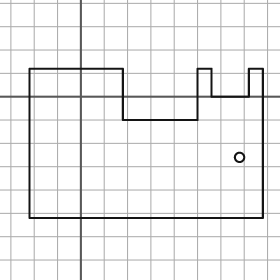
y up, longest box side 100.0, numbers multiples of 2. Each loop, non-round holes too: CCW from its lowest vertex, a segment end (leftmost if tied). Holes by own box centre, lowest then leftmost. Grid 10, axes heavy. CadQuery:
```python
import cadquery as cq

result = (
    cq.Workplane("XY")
    .moveTo(-22.0, -52.0)
    .lineTo(78.0, -52.0)
    .lineTo(78.0, 12.0)
    .lineTo(72.0, 12.0)
    .lineTo(72.0, 0.0)
    .lineTo(56.0, 0.0)
    .lineTo(56.0, 12.0)
    .lineTo(50.0, 12.0)
    .lineTo(50.0, -10.0)
    .lineTo(18.0, -10.0)
    .lineTo(18.0, 12.0)
    .lineTo(-22.0, 12.0)
    .close()
    .moveTo(68.0, -26.0)
    .circle(2.0)
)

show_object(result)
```